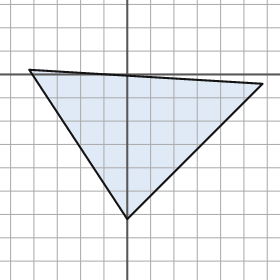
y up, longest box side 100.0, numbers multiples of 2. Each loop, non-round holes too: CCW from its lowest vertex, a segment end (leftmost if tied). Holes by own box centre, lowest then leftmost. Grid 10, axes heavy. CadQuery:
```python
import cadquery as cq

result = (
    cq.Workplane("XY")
    .moveTo(0.0, -62.0)
    .lineTo(58.0, -4.0)
    .lineTo(-42.0, 2.0)
    .close()
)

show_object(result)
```